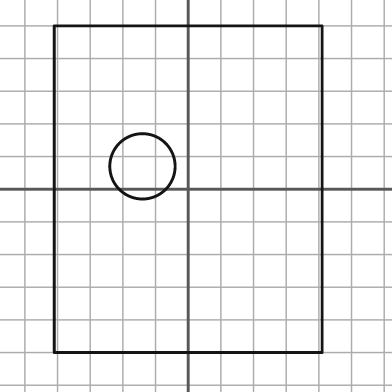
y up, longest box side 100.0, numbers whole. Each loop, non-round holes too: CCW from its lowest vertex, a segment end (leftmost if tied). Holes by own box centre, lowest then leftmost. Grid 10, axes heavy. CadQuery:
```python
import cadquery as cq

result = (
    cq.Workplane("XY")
    .moveTo(-41.0, -50.0)
    .lineTo(41.0, -50.0)
    .lineTo(41.0, 50.0)
    .lineTo(-41.0, 50.0)
    .close()
    .moveTo(-14.0, 7.0)
    .circle(10.0)
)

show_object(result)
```